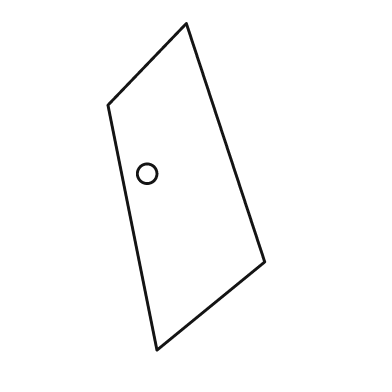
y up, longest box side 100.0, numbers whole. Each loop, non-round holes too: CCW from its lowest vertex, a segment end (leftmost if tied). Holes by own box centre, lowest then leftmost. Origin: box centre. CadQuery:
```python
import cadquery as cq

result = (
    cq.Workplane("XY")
    .moveTo(-9.0, -50.0)
    .lineTo(24.0, -23.0)
    .lineTo(0.0, 50.0)
    .lineTo(-24.0, 25.0)
    .close()
    .moveTo(-12.0, 4.0)
    .circle(3.0)
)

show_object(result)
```